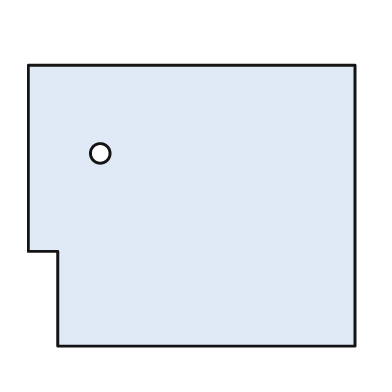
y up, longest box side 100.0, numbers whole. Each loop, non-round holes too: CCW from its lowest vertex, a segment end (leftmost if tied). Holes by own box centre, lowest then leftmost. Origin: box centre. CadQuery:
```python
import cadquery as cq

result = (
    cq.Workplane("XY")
    .moveTo(-41.0, -43.0)
    .lineTo(50.0, -43.0)
    .lineTo(50.0, 43.0)
    .lineTo(-50.0, 43.0)
    .lineTo(-50.0, -14.0)
    .lineTo(-41.0, -14.0)
    .close()
    .moveTo(-28.0, 16.0)
    .circle(3.0)
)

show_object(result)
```